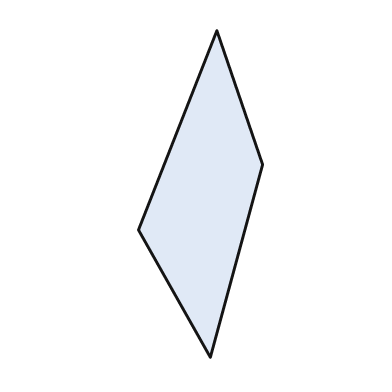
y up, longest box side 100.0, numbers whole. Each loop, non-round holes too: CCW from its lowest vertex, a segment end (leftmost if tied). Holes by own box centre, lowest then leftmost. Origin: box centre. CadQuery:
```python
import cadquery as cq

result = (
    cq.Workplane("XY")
    .moveTo(3.0, -50.0)
    .lineTo(19.0, 9.0)
    .lineTo(5.0, 50.0)
    .lineTo(-19.0, -11.0)
    .close()
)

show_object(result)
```